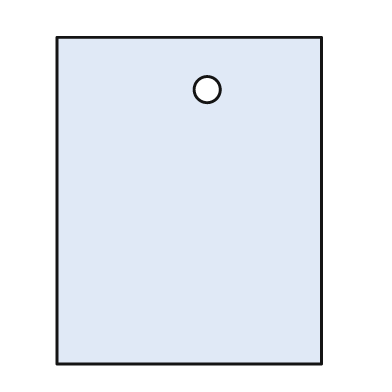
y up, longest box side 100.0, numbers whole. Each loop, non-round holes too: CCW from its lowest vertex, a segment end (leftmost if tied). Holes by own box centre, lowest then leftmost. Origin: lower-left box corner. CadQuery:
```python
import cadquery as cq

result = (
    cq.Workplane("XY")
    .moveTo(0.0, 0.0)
    .lineTo(81.0, 0.0)
    .lineTo(81.0, 100.0)
    .lineTo(0.0, 100.0)
    .close()
    .moveTo(46.0, 84.0)
    .circle(4.0)
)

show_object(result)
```